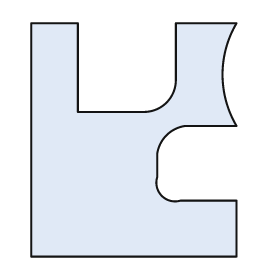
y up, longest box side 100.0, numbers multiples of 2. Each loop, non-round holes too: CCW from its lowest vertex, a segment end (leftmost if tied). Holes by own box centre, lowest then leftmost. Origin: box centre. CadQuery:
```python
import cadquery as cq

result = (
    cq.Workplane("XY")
    .moveTo(-44.0, -50.0)
    .lineTo(44.0, -50.0)
    .lineTo(44.0, -26.0)
    .lineTo(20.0, -26.0)
    .threePointArc((12.0, -24.0), (10.0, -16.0))
    .lineTo(10.0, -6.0)
    .threePointArc((14.0, 2.0), (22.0, 6.0))
    .lineTo(44.0, 6.0)
    .threePointArc((38.0, 28.0), (44.0, 50.0))
    .lineTo(18.0, 50.0)
    .lineTo(18.0, 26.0)
    .threePointArc((14.0, 16.0), (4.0, 12.0))
    .lineTo(-24.0, 12.0)
    .lineTo(-24.0, 50.0)
    .lineTo(-44.0, 50.0)
    .close()
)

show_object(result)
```